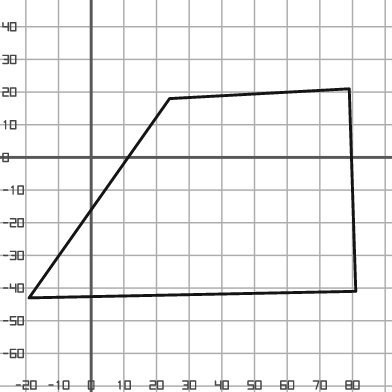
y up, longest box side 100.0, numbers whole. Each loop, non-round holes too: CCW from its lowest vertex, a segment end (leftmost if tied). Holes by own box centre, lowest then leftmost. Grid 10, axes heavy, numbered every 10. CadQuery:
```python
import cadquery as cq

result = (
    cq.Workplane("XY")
    .moveTo(-19.0, -43.0)
    .lineTo(81.0, -41.0)
    .lineTo(79.0, 21.0)
    .lineTo(24.0, 18.0)
    .close()
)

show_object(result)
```